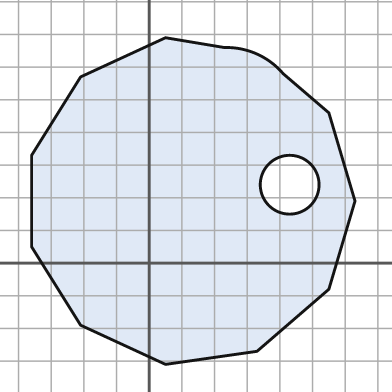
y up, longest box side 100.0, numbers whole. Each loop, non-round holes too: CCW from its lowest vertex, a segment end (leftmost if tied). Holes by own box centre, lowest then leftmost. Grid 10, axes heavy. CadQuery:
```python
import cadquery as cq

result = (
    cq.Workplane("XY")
    .moveTo(5.0, -31.0)
    .lineTo(33.0, -27.0)
    .lineTo(55.0, -8.0)
    .lineTo(63.0, 19.0)
    .lineTo(55.0, 46.0)
    .lineTo(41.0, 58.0)
    .threePointArc((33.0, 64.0), (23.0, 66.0))
    .lineTo(5.0, 69.0)
    .lineTo(-21.0, 57.0)
    .lineTo(-36.0, 33.0)
    .lineTo(-36.0, 5.0)
    .lineTo(-21.0, -19.0)
    .close()
    .moveTo(43.0, 24.0)
    .circle(9.0)
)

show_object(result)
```